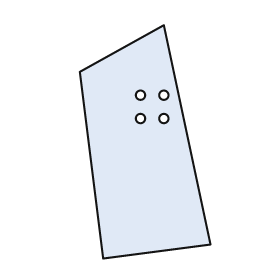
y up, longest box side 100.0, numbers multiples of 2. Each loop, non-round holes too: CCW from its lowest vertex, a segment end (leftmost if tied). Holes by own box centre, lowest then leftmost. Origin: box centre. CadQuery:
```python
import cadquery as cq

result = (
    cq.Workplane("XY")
    .moveTo(-18.0, -50.0)
    .lineTo(28.0, -44.0)
    .lineTo(8.0, 50.0)
    .lineTo(-28.0, 30.0)
    .close()
    .moveTo(-2.0, 10.0)
    .circle(2.0)
    .moveTo(8.0, 10.0)
    .circle(2.0)
    .moveTo(-2.0, 20.0)
    .circle(2.0)
    .moveTo(8.0, 20.0)
    .circle(2.0)
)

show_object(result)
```